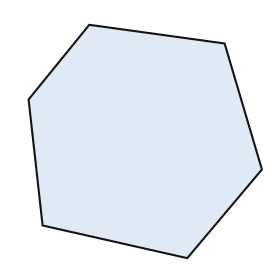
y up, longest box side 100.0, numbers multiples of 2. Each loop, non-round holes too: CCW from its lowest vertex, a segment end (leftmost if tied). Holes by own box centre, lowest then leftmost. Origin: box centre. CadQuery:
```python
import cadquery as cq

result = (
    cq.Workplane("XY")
    .moveTo(18.0, -50.0)
    .lineTo(50.0, -12.0)
    .lineTo(34.0, 42.0)
    .lineTo(-24.0, 50.0)
    .lineTo(-50.0, 18.0)
    .lineTo(-44.0, -36.0)
    .close()
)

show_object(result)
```